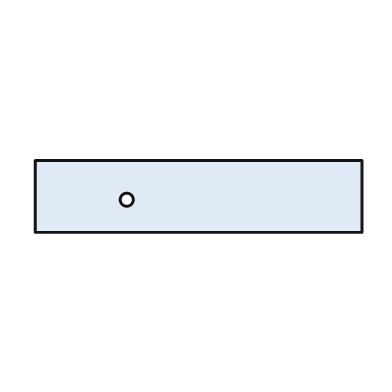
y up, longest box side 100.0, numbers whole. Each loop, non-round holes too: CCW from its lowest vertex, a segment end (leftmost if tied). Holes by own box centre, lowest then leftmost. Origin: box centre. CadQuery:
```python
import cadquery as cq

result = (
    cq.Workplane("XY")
    .moveTo(-50.0, -11.0)
    .lineTo(50.0, -11.0)
    .lineTo(50.0, 11.0)
    .lineTo(-50.0, 11.0)
    .close()
    .moveTo(-22.0, -1.0)
    .circle(2.0)
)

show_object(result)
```